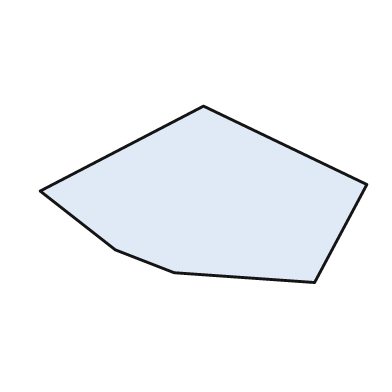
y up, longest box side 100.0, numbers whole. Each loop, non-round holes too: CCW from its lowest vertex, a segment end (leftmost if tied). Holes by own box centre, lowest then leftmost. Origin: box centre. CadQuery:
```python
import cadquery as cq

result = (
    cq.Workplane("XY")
    .moveTo(34.0, -27.0)
    .lineTo(50.0, 3.0)
    .lineTo(0.0, 27.0)
    .lineTo(-50.0, 1.0)
    .lineTo(-27.0, -17.0)
    .lineTo(-9.0, -24.0)
    .close()
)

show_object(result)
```